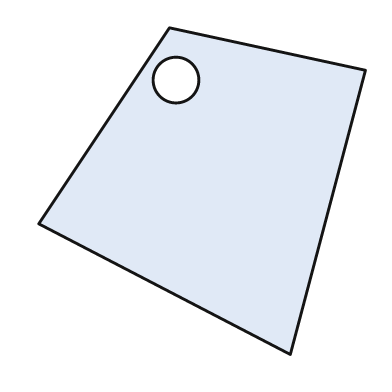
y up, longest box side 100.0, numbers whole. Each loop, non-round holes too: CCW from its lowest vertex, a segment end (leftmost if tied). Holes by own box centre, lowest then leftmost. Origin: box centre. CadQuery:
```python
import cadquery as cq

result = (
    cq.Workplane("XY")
    .moveTo(27.0, -50.0)
    .lineTo(50.0, 37.0)
    .lineTo(-10.0, 50.0)
    .lineTo(-50.0, -10.0)
    .close()
    .moveTo(-8.0, 34.0)
    .circle(7.0)
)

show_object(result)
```